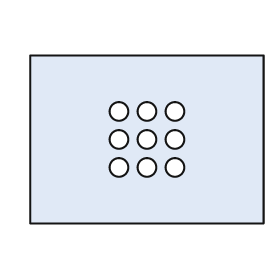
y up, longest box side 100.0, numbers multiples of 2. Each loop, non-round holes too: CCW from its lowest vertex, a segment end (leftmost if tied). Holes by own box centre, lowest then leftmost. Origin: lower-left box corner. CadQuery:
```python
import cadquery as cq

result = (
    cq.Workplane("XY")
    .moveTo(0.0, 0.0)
    .lineTo(100.0, 0.0)
    .lineTo(100.0, 72.0)
    .lineTo(0.0, 72.0)
    .close()
    .moveTo(38.0, 24.0)
    .circle(4.0)
    .moveTo(50.0, 24.0)
    .circle(4.0)
    .moveTo(62.0, 24.0)
    .circle(4.0)
    .moveTo(38.0, 36.0)
    .circle(4.0)
    .moveTo(50.0, 36.0)
    .circle(4.0)
    .moveTo(62.0, 36.0)
    .circle(4.0)
    .moveTo(38.0, 48.0)
    .circle(4.0)
    .moveTo(50.0, 48.0)
    .circle(4.0)
    .moveTo(62.0, 48.0)
    .circle(4.0)
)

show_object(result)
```